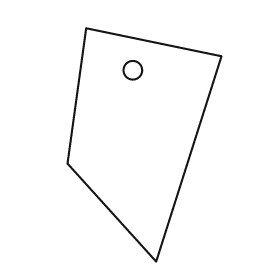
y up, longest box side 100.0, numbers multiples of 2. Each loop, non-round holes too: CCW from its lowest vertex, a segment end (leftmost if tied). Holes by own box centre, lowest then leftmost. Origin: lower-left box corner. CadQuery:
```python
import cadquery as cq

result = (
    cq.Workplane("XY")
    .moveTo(38.0, 0.0)
    .lineTo(66.0, 88.0)
    .lineTo(8.0, 100.0)
    .lineTo(0.0, 42.0)
    .close()
    .moveTo(28.0, 82.0)
    .circle(4.0)
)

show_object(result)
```